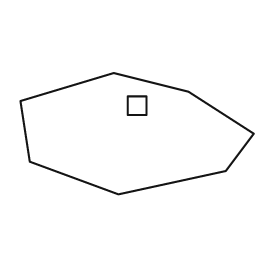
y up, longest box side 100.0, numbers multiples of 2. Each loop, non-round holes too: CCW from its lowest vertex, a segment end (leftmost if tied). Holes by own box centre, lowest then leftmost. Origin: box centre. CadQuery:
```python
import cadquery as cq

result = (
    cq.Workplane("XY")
    .moveTo(-8.0, -26.0)
    .lineTo(38.0, -16.0)
    .lineTo(50.0, 0.0)
    .lineTo(22.0, 18.0)
    .lineTo(-10.0, 26.0)
    .lineTo(-50.0, 14.0)
    .lineTo(-46.0, -12.0)
    .close()
    .moveTo(-4.0, 8.0)
    .lineTo(4.0, 8.0)
    .lineTo(4.0, 16.0)
    .lineTo(-4.0, 16.0)
    .close()
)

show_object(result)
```